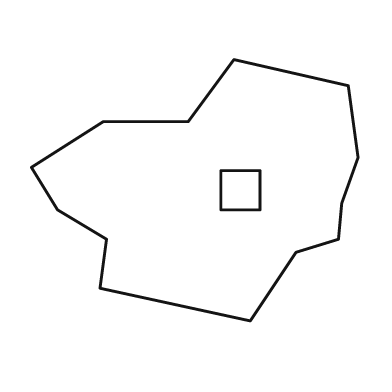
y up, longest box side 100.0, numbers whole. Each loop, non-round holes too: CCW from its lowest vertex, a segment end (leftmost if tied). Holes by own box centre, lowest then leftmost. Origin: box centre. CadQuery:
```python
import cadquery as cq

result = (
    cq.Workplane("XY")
    .moveTo(17.0, -40.0)
    .lineTo(31.0, -19.0)
    .lineTo(44.0, -15.0)
    .lineTo(45.0, -4.0)
    .lineTo(50.0, 10.0)
    .lineTo(47.0, 32.0)
    .lineTo(12.0, 40.0)
    .lineTo(-2.0, 21.0)
    .lineTo(-28.0, 21.0)
    .lineTo(-50.0, 7.0)
    .lineTo(-42.0, -6.0)
    .lineTo(-27.0, -15.0)
    .lineTo(-29.0, -30.0)
    .close()
    .moveTo(8.0, -6.0)
    .lineTo(20.0, -6.0)
    .lineTo(20.0, 6.0)
    .lineTo(8.0, 6.0)
    .close()
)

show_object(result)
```